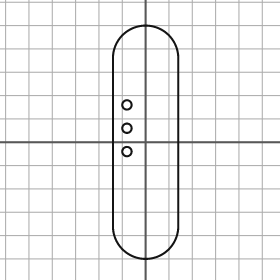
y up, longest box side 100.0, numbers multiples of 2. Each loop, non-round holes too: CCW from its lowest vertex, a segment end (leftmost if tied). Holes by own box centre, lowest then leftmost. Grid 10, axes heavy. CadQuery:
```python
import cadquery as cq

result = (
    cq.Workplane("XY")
    .moveTo(-14.0, -36.0)
    .threePointArc((0.0, -50.0), (14.0, -36.0))
    .lineTo(14.0, 36.0)
    .threePointArc((0.0, 50.0), (-14.0, 36.0))
    .close()
    .moveTo(-8.0, -4.0)
    .circle(2.0)
    .moveTo(-8.0, 6.0)
    .circle(2.0)
    .moveTo(-8.0, 16.0)
    .circle(2.0)
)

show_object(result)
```